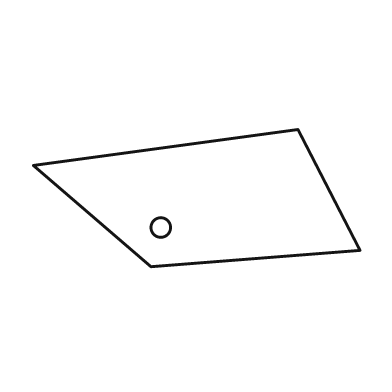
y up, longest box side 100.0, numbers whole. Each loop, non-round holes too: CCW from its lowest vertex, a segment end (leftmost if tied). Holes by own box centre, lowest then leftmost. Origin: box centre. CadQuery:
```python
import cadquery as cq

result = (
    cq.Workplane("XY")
    .moveTo(-14.0, -21.0)
    .lineTo(50.0, -16.0)
    .lineTo(31.0, 21.0)
    .lineTo(-50.0, 10.0)
    .close()
    .moveTo(-11.0, -9.0)
    .circle(3.0)
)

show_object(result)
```